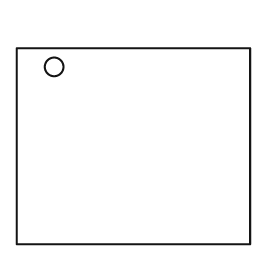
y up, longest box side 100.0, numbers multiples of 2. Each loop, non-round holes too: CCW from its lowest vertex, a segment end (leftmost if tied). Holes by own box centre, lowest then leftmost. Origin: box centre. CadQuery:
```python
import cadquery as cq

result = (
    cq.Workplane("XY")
    .moveTo(-50.0, -42.0)
    .lineTo(50.0, -42.0)
    .lineTo(50.0, 42.0)
    .lineTo(-50.0, 42.0)
    .close()
    .moveTo(-34.0, 34.0)
    .circle(4.0)
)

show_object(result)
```